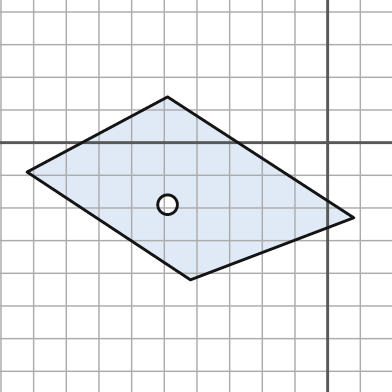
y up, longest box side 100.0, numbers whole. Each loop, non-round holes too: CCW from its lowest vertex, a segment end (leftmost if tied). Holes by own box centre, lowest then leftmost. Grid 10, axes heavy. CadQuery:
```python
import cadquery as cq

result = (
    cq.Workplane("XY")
    .moveTo(-42.0, -42.0)
    .lineTo(8.0, -23.0)
    .lineTo(-49.0, 14.0)
    .lineTo(-92.0, -9.0)
    .close()
    .moveTo(-49.0, -19.0)
    .circle(3.0)
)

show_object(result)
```